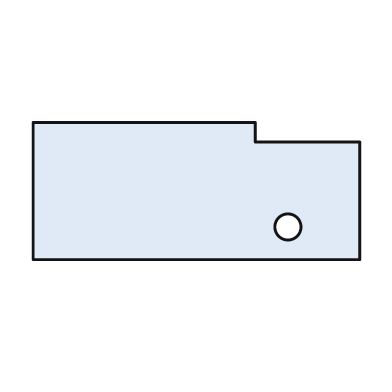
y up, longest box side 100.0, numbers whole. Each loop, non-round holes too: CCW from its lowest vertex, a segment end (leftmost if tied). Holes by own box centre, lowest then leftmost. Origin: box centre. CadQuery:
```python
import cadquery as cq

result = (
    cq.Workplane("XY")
    .moveTo(-50.0, -21.0)
    .lineTo(50.0, -21.0)
    .lineTo(50.0, 15.0)
    .lineTo(18.0, 15.0)
    .lineTo(18.0, 21.0)
    .lineTo(-50.0, 21.0)
    .close()
    .moveTo(28.0, -11.0)
    .circle(4.0)
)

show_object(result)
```